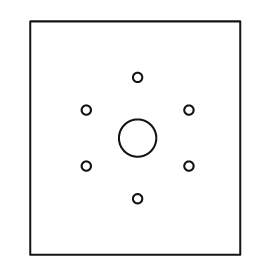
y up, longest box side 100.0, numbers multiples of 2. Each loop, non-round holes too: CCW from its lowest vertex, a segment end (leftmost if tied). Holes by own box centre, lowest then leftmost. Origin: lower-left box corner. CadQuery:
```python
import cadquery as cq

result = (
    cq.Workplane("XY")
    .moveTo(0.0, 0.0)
    .lineTo(90.0, 0.0)
    .lineTo(90.0, 100.0)
    .lineTo(0.0, 100.0)
    .close()
    .moveTo(46.0, 24.0)
    .circle(2.0)
    .moveTo(24.0, 38.0)
    .circle(2.0)
    .moveTo(68.0, 38.0)
    .circle(2.0)
    .moveTo(46.0, 50.0)
    .circle(8.0)
    .moveTo(24.0, 62.0)
    .circle(2.0)
    .moveTo(68.0, 62.0)
    .circle(2.0)
    .moveTo(46.0, 76.0)
    .circle(2.0)
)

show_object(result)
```